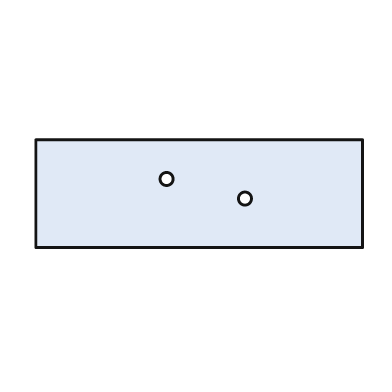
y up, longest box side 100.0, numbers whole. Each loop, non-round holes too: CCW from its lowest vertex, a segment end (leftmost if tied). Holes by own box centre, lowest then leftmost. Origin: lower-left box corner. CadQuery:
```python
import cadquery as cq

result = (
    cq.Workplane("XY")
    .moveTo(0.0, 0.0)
    .lineTo(100.0, 0.0)
    .lineTo(100.0, 33.0)
    .lineTo(0.0, 33.0)
    .close()
    .moveTo(64.0, 15.0)
    .circle(2.0)
    .moveTo(40.0, 21.0)
    .circle(2.0)
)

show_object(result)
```